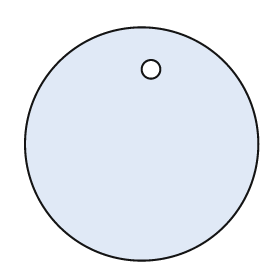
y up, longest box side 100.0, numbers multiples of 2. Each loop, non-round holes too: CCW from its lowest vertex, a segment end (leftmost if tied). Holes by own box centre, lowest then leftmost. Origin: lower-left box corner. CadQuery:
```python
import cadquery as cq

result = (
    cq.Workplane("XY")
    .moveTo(50.0, 50.0)
    .circle(50.0)
    .moveTo(54.0, 82.0)
    .circle(4.0)
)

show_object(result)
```